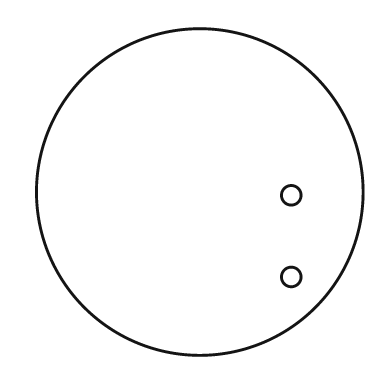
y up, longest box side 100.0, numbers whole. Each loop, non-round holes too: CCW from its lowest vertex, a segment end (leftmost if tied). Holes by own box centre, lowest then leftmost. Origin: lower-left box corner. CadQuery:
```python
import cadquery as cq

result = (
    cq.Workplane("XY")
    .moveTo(50.0, 50.0)
    .circle(50.0)
    .moveTo(78.0, 24.0)
    .circle(3.0)
    .moveTo(78.0, 49.0)
    .circle(3.0)
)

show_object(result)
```